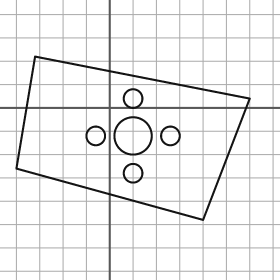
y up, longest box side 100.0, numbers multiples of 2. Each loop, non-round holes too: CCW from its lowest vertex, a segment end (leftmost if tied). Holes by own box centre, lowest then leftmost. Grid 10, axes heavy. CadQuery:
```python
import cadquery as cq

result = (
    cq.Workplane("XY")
    .moveTo(40.0, -48.0)
    .lineTo(60.0, 4.0)
    .lineTo(-32.0, 22.0)
    .lineTo(-40.0, -26.0)
    .close()
    .moveTo(10.0, -28.0)
    .circle(4.0)
    .moveTo(-6.0, -12.0)
    .circle(4.0)
    .moveTo(10.0, -12.0)
    .circle(8.0)
    .moveTo(26.0, -12.0)
    .circle(4.0)
    .moveTo(10.0, 4.0)
    .circle(4.0)
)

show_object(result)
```